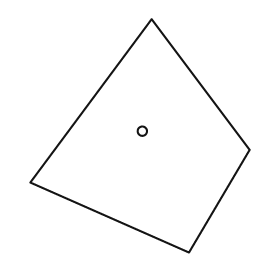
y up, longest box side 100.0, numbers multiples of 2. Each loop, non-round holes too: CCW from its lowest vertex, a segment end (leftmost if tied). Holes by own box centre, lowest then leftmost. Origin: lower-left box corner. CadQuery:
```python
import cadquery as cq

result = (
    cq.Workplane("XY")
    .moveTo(68.0, 0.0)
    .lineTo(94.0, 44.0)
    .lineTo(52.0, 100.0)
    .lineTo(0.0, 30.0)
    .close()
    .moveTo(48.0, 52.0)
    .circle(2.0)
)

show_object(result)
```